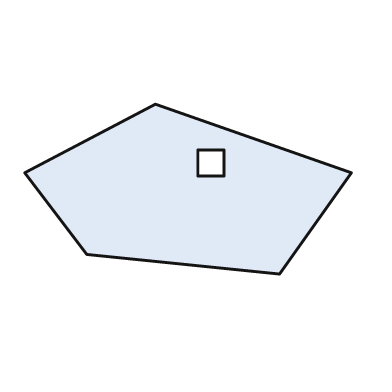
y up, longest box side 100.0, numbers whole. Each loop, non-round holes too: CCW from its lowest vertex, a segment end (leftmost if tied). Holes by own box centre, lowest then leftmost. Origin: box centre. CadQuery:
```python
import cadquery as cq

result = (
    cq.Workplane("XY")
    .moveTo(28.0, -26.0)
    .lineTo(50.0, 5.0)
    .lineTo(-10.0, 26.0)
    .lineTo(-50.0, 5.0)
    .lineTo(-31.0, -20.0)
    .close()
    .moveTo(3.0, 4.0)
    .lineTo(11.0, 4.0)
    .lineTo(11.0, 12.0)
    .lineTo(3.0, 12.0)
    .close()
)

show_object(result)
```